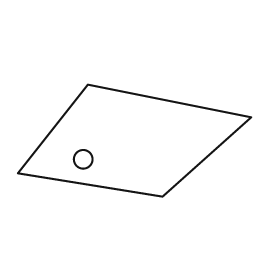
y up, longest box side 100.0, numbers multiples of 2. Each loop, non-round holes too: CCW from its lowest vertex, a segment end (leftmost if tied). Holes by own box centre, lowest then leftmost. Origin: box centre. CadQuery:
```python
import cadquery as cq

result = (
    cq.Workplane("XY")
    .moveTo(12.0, -24.0)
    .lineTo(50.0, 10.0)
    .lineTo(-20.0, 24.0)
    .lineTo(-50.0, -14.0)
    .close()
    .moveTo(-22.0, -8.0)
    .circle(4.0)
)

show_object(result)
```